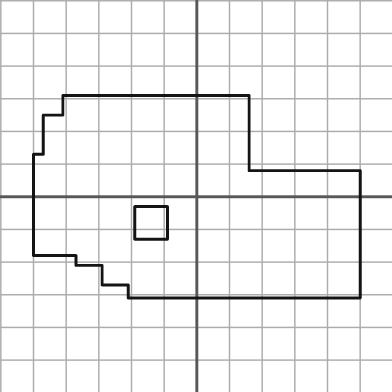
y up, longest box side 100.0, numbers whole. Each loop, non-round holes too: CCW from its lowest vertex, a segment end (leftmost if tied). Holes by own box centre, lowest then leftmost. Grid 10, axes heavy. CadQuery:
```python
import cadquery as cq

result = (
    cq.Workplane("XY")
    .moveTo(-21.0, -31.0)
    .lineTo(50.0, -31.0)
    .lineTo(50.0, 8.0)
    .lineTo(16.0, 8.0)
    .lineTo(16.0, 31.0)
    .lineTo(-41.0, 31.0)
    .lineTo(-41.0, 25.0)
    .lineTo(-47.0, 25.0)
    .lineTo(-47.0, 13.0)
    .lineTo(-50.0, 13.0)
    .lineTo(-50.0, -18.0)
    .lineTo(-37.0, -18.0)
    .lineTo(-37.0, -21.0)
    .lineTo(-29.0, -21.0)
    .lineTo(-29.0, -27.0)
    .lineTo(-21.0, -27.0)
    .close()
    .moveTo(-19.0, -13.0)
    .lineTo(-9.0, -13.0)
    .lineTo(-9.0, -3.0)
    .lineTo(-19.0, -3.0)
    .close()
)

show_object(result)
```